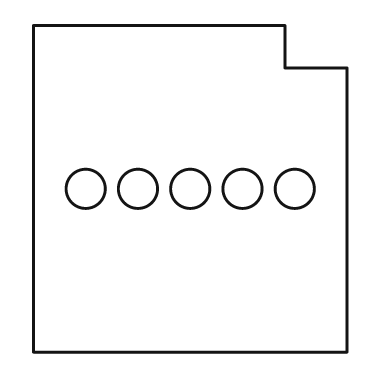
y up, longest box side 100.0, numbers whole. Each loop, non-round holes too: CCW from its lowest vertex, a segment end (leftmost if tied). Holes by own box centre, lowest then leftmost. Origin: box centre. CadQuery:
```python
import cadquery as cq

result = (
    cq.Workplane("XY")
    .moveTo(-48.0, -50.0)
    .lineTo(48.0, -50.0)
    .lineTo(48.0, 37.0)
    .lineTo(29.0, 37.0)
    .lineTo(29.0, 50.0)
    .lineTo(-48.0, 50.0)
    .close()
    .moveTo(-32.0, 0.0)
    .circle(6.0)
    .moveTo(-16.0, 0.0)
    .circle(6.0)
    .moveTo(0.0, 0.0)
    .circle(6.0)
    .moveTo(16.0, 0.0)
    .circle(6.0)
    .moveTo(32.0, 0.0)
    .circle(6.0)
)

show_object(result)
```